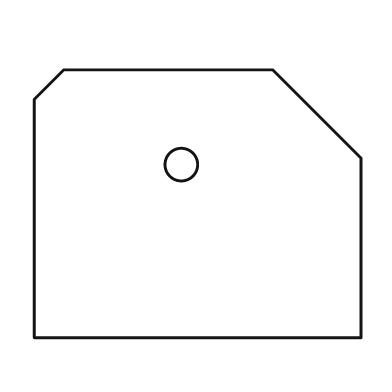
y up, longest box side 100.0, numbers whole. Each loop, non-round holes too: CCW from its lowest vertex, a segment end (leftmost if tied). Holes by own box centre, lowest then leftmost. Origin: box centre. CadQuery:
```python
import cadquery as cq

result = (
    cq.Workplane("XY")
    .moveTo(-50.0, -41.0)
    .lineTo(50.0, -41.0)
    .lineTo(50.0, 14.0)
    .lineTo(23.0, 41.0)
    .lineTo(-41.0, 41.0)
    .lineTo(-50.0, 32.0)
    .close()
    .moveTo(-5.0, 12.0)
    .circle(5.0)
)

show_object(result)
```